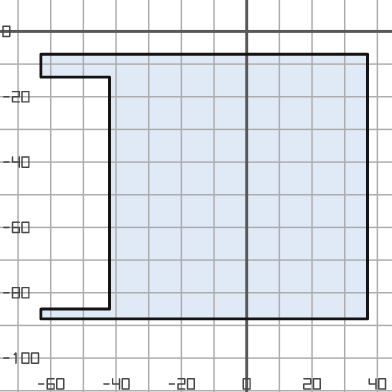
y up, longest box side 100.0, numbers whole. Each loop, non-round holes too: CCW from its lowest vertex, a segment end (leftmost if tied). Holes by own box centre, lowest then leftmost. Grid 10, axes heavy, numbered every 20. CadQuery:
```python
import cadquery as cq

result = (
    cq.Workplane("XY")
    .moveTo(-63.0, -88.0)
    .lineTo(37.0, -88.0)
    .lineTo(37.0, -7.0)
    .lineTo(-63.0, -7.0)
    .lineTo(-63.0, -14.0)
    .lineTo(-42.0, -14.0)
    .lineTo(-42.0, -85.0)
    .lineTo(-63.0, -85.0)
    .close()
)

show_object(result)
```